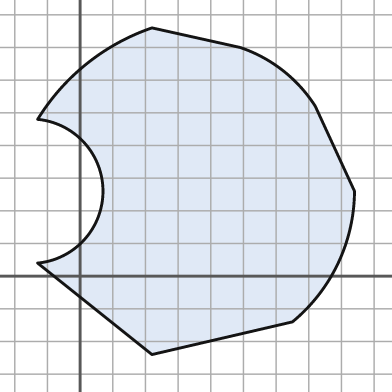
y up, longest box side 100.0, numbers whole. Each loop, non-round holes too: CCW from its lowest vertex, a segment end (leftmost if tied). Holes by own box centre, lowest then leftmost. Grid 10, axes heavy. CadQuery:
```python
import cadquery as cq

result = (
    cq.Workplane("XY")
    .moveTo(22.0, -24.0)
    .lineTo(65.0, -14.0)
    .threePointArc((79.0, 4.0), (84.0, 26.0))
    .lineTo(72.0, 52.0)
    .threePointArc((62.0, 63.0), (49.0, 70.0))
    .lineTo(22.0, 76.0)
    .threePointArc((2.0, 65.0), (-13.0, 48.0))
    .threePointArc((7.0, 26.0), (-13.0, 4.0))
    .close()
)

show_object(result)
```